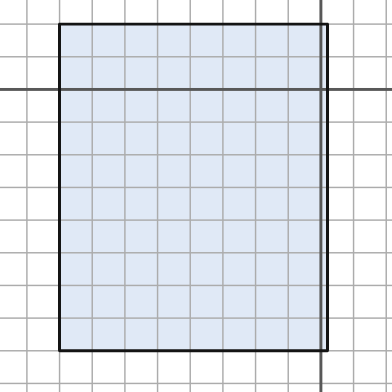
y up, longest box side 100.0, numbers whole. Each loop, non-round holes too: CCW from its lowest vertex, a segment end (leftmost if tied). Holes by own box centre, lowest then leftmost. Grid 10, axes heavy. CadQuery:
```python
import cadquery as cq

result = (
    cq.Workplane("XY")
    .moveTo(-80.0, -80.0)
    .lineTo(2.0, -80.0)
    .lineTo(2.0, 20.0)
    .lineTo(-80.0, 20.0)
    .close()
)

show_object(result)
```